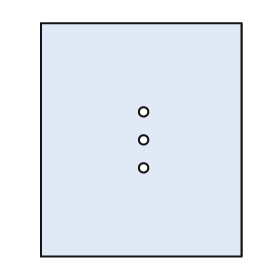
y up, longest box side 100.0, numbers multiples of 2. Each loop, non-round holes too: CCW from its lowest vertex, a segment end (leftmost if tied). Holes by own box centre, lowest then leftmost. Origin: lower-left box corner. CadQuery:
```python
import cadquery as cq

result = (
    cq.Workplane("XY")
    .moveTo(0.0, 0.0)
    .lineTo(86.0, 0.0)
    .lineTo(86.0, 100.0)
    .lineTo(0.0, 100.0)
    .close()
    .moveTo(44.0, 38.0)
    .circle(2.0)
    .moveTo(44.0, 50.0)
    .circle(2.0)
    .moveTo(44.0, 62.0)
    .circle(2.0)
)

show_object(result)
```